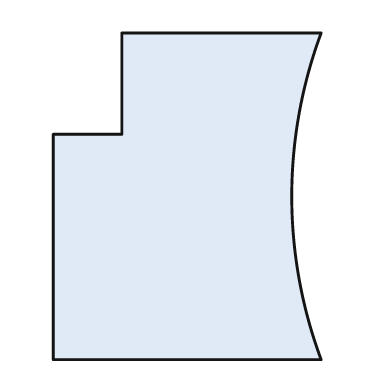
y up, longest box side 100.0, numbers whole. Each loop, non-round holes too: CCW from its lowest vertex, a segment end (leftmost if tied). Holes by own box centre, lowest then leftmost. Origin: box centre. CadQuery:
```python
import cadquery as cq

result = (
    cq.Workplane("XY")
    .moveTo(-41.0, -50.0)
    .lineTo(41.0, -50.0)
    .threePointArc((32.0, 0.0), (41.0, 50.0))
    .lineTo(-20.0, 50.0)
    .lineTo(-20.0, 19.0)
    .lineTo(-41.0, 19.0)
    .close()
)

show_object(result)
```